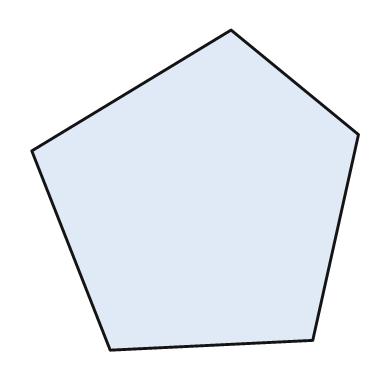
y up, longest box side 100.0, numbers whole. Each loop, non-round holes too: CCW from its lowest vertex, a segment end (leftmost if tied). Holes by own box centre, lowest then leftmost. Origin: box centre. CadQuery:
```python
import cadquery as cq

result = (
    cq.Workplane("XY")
    .moveTo(-26.0, -49.0)
    .lineTo(36.0, -46.0)
    .lineTo(50.0, 17.0)
    .lineTo(11.0, 49.0)
    .lineTo(-50.0, 12.0)
    .close()
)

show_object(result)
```